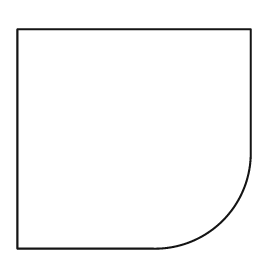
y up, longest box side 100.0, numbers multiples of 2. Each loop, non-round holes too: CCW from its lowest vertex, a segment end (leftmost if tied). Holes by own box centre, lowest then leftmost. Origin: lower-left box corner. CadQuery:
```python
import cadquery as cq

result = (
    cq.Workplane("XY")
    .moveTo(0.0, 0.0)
    .lineTo(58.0, 0.0)
    .threePointArc((88.0, 12.0), (100.0, 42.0))
    .lineTo(100.0, 94.0)
    .lineTo(0.0, 94.0)
    .close()
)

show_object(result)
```